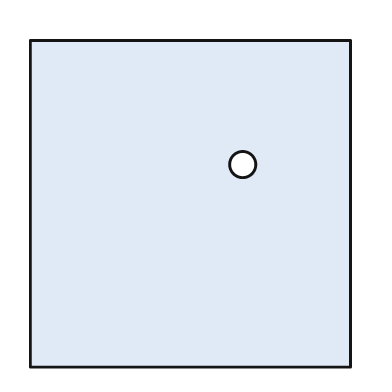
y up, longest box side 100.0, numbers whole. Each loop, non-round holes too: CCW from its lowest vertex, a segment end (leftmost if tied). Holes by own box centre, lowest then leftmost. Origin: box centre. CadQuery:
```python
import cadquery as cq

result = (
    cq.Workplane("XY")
    .moveTo(-49.0, -50.0)
    .lineTo(49.0, -50.0)
    .lineTo(49.0, 50.0)
    .lineTo(-49.0, 50.0)
    .close()
    .moveTo(16.0, 12.0)
    .circle(4.0)
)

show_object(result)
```